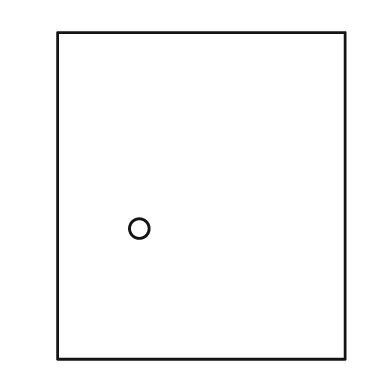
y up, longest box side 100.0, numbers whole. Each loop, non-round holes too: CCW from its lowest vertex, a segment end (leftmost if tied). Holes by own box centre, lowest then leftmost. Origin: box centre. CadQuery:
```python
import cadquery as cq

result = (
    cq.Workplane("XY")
    .moveTo(-44.0, -50.0)
    .lineTo(44.0, -50.0)
    .lineTo(44.0, 50.0)
    .lineTo(-44.0, 50.0)
    .close()
    .moveTo(-19.0, -10.0)
    .circle(3.0)
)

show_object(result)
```